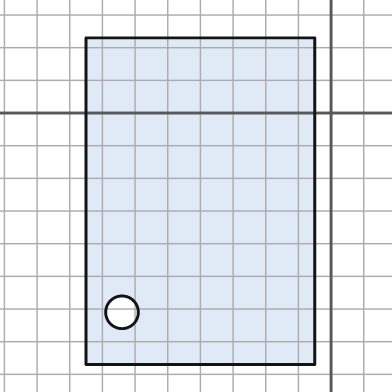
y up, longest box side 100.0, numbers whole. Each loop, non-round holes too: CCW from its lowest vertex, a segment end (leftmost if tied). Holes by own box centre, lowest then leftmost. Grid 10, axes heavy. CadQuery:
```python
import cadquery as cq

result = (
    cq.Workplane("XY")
    .moveTo(-75.0, -77.0)
    .lineTo(-5.0, -77.0)
    .lineTo(-5.0, 23.0)
    .lineTo(-75.0, 23.0)
    .close()
    .moveTo(-64.0, -61.0)
    .circle(5.0)
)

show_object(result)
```